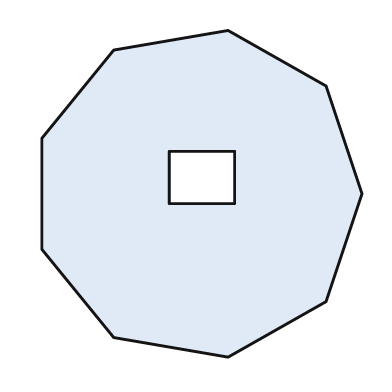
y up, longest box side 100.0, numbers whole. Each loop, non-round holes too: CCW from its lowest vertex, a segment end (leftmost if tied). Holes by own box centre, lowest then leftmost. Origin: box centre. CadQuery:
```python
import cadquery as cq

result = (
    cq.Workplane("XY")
    .moveTo(8.0, -50.0)
    .lineTo(38.0, -33.0)
    .lineTo(49.0, 0.0)
    .lineTo(38.0, 33.0)
    .lineTo(8.0, 50.0)
    .lineTo(-27.0, 44.0)
    .lineTo(-49.0, 17.0)
    .lineTo(-49.0, -17.0)
    .lineTo(-27.0, -44.0)
    .close()
    .moveTo(-10.0, -3.0)
    .lineTo(10.0, -3.0)
    .lineTo(10.0, 13.0)
    .lineTo(-10.0, 13.0)
    .close()
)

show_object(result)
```